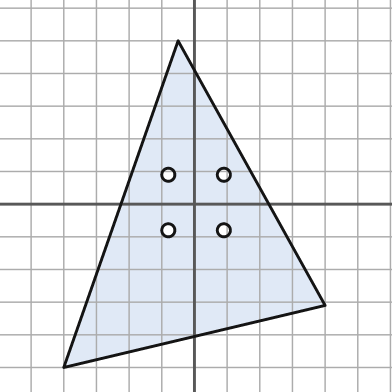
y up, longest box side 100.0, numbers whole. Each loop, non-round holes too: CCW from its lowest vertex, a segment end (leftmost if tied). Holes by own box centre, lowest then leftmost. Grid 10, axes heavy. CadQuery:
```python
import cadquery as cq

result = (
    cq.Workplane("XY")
    .moveTo(-40.0, -50.0)
    .lineTo(40.0, -31.0)
    .lineTo(-5.0, 50.0)
    .close()
    .moveTo(-8.0, -8.0)
    .circle(2.0)
    .moveTo(9.0, -8.0)
    .circle(2.0)
    .moveTo(-8.0, 9.0)
    .circle(2.0)
    .moveTo(9.0, 9.0)
    .circle(2.0)
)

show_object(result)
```